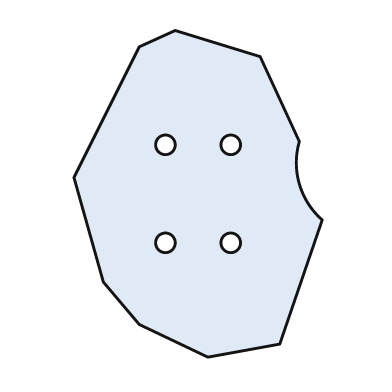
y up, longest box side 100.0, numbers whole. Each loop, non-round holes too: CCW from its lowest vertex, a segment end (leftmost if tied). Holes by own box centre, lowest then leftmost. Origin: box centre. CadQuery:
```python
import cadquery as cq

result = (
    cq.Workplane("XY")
    .moveTo(3.0, -50.0)
    .lineTo(25.0, -46.0)
    .lineTo(38.0, -8.0)
    .threePointArc((31.0, 3.0), (31.0, 16.0))
    .lineTo(19.0, 42.0)
    .lineTo(-7.0, 50.0)
    .lineTo(-18.0, 45.0)
    .lineTo(-38.0, 5.0)
    .lineTo(-29.0, -27.0)
    .lineTo(-18.0, -40.0)
    .close()
    .moveTo(-10.0, -15.0)
    .circle(3.0)
    .moveTo(10.0, -15.0)
    .circle(3.0)
    .moveTo(-10.0, 15.0)
    .circle(3.0)
    .moveTo(10.0, 15.0)
    .circle(3.0)
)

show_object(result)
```